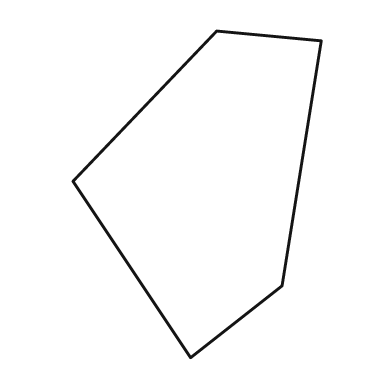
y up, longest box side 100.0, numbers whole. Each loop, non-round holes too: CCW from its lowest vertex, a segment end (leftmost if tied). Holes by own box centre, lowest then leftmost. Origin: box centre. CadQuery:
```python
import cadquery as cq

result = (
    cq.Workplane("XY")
    .moveTo(-2.0, -50.0)
    .lineTo(26.0, -28.0)
    .lineTo(38.0, 47.0)
    .lineTo(6.0, 50.0)
    .lineTo(-38.0, 4.0)
    .close()
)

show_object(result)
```